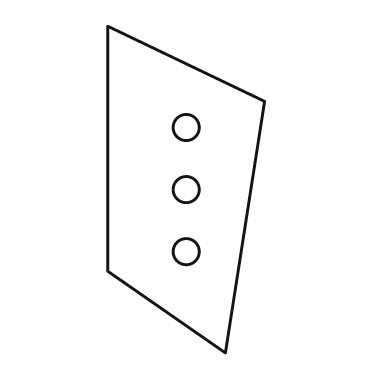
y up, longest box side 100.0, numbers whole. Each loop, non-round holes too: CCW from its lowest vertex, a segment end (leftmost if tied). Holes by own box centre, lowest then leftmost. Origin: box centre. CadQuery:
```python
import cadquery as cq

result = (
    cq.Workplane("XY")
    .moveTo(12.0, -50.0)
    .lineTo(24.0, 27.0)
    .lineTo(-24.0, 50.0)
    .lineTo(-24.0, -25.0)
    .close()
    .moveTo(0.0, -19.0)
    .circle(4.0)
    .moveTo(0.0, 0.0)
    .circle(4.0)
    .moveTo(0.0, 19.0)
    .circle(4.0)
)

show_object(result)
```